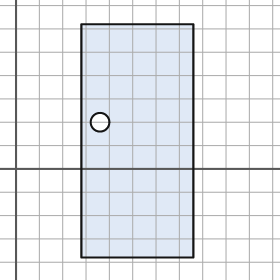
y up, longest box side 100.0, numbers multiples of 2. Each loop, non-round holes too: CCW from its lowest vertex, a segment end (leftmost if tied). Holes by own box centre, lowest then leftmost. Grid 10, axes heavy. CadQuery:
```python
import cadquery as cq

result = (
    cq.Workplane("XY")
    .moveTo(28.0, -38.0)
    .lineTo(76.0, -38.0)
    .lineTo(76.0, 62.0)
    .lineTo(28.0, 62.0)
    .close()
    .moveTo(36.0, 20.0)
    .circle(4.0)
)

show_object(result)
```